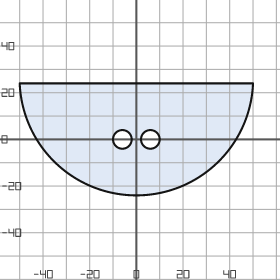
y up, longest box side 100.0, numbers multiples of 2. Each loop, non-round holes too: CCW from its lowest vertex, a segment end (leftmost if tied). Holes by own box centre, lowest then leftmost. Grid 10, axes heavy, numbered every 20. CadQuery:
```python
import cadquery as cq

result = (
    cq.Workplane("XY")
    .moveTo(-50.0, 24.0)
    .threePointArc((0.0, -24.0), (50.0, 24.0))
    .close()
    .moveTo(-6.0, 0.0)
    .circle(4.0)
    .moveTo(6.0, 0.0)
    .circle(4.0)
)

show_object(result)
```